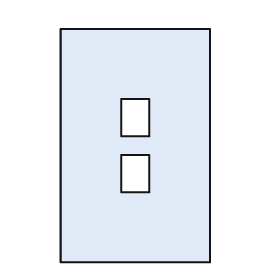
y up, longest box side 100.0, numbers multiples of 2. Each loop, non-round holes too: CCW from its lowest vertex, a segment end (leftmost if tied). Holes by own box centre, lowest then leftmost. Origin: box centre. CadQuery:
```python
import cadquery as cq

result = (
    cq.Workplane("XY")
    .moveTo(-32.0, -50.0)
    .lineTo(32.0, -50.0)
    .lineTo(32.0, 50.0)
    .lineTo(-32.0, 50.0)
    .close()
    .moveTo(-6.0, -20.0)
    .lineTo(6.0, -20.0)
    .lineTo(6.0, -4.0)
    .lineTo(-6.0, -4.0)
    .close()
    .moveTo(-6.0, 4.0)
    .lineTo(6.0, 4.0)
    .lineTo(6.0, 20.0)
    .lineTo(-6.0, 20.0)
    .close()
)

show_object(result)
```